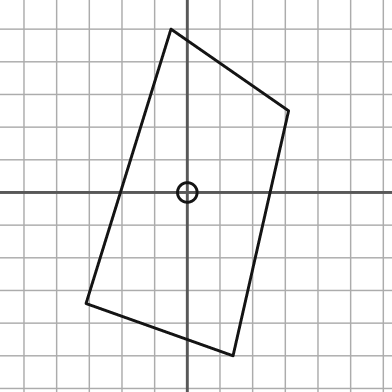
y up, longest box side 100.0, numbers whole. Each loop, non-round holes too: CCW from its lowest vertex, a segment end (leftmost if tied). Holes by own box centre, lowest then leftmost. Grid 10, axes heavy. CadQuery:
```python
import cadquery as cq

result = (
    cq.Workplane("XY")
    .moveTo(14.0, -50.0)
    .lineTo(31.0, 25.0)
    .lineTo(-5.0, 50.0)
    .lineTo(-31.0, -34.0)
    .close()
    .moveTo(0.0, 0.0)
    .circle(3.0)
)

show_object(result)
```